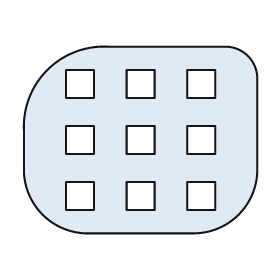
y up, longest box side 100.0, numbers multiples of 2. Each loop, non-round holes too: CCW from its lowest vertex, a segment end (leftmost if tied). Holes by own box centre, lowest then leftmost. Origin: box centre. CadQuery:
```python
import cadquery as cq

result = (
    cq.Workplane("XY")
    .moveTo(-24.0, -40.0)
    .lineTo(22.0, -40.0)
    .threePointArc((42.0, -32.0), (50.0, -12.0))
    .lineTo(50.0, 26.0)
    .threePointArc((46.0, 36.0), (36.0, 40.0))
    .lineTo(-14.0, 40.0)
    .threePointArc((-40.0, 30.0), (-50.0, 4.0))
    .lineTo(-50.0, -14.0)
    .threePointArc((-42.0, -32.0), (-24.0, -40.0))
    .close()
    .moveTo(-32.0, -30.0)
    .lineTo(-20.0, -30.0)
    .lineTo(-20.0, -18.0)
    .lineTo(-32.0, -18.0)
    .close()
    .moveTo(-6.0, -30.0)
    .lineTo(6.0, -30.0)
    .lineTo(6.0, -18.0)
    .lineTo(-6.0, -18.0)
    .close()
    .moveTo(20.0, -30.0)
    .lineTo(32.0, -30.0)
    .lineTo(32.0, -18.0)
    .lineTo(20.0, -18.0)
    .close()
    .moveTo(-32.0, -6.0)
    .lineTo(-20.0, -6.0)
    .lineTo(-20.0, 6.0)
    .lineTo(-32.0, 6.0)
    .close()
    .moveTo(-6.0, -6.0)
    .lineTo(6.0, -6.0)
    .lineTo(6.0, 6.0)
    .lineTo(-6.0, 6.0)
    .close()
    .moveTo(20.0, -6.0)
    .lineTo(32.0, -6.0)
    .lineTo(32.0, 6.0)
    .lineTo(20.0, 6.0)
    .close()
    .moveTo(-32.0, 18.0)
    .lineTo(-20.0, 18.0)
    .lineTo(-20.0, 30.0)
    .lineTo(-32.0, 30.0)
    .close()
    .moveTo(-6.0, 18.0)
    .lineTo(6.0, 18.0)
    .lineTo(6.0, 30.0)
    .lineTo(-6.0, 30.0)
    .close()
    .moveTo(20.0, 18.0)
    .lineTo(32.0, 18.0)
    .lineTo(32.0, 30.0)
    .lineTo(20.0, 30.0)
    .close()
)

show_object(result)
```